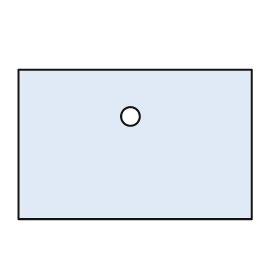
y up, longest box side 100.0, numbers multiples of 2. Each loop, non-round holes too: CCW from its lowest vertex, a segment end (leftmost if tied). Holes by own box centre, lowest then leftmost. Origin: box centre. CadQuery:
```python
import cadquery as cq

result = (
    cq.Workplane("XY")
    .moveTo(-50.0, -32.0)
    .lineTo(50.0, -32.0)
    .lineTo(50.0, 32.0)
    .lineTo(-50.0, 32.0)
    .close()
    .moveTo(-2.0, 12.0)
    .circle(4.0)
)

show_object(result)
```